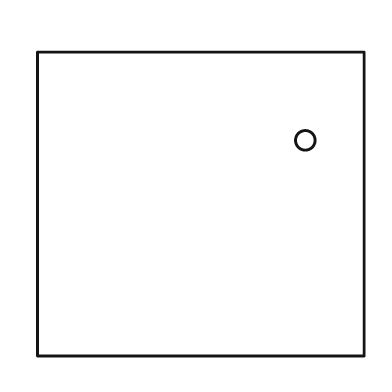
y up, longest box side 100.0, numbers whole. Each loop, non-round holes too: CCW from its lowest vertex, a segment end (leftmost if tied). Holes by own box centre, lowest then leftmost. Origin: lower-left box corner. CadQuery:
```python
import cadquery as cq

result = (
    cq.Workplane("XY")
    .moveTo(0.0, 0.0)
    .lineTo(100.0, 0.0)
    .lineTo(100.0, 93.0)
    .lineTo(0.0, 93.0)
    .close()
    .moveTo(82.0, 66.0)
    .circle(3.0)
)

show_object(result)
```